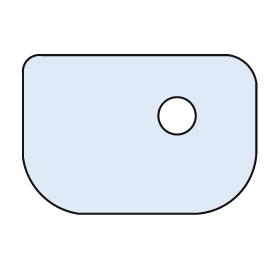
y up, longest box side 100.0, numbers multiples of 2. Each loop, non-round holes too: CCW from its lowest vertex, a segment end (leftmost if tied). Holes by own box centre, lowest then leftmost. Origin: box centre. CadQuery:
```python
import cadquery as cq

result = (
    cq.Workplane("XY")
    .moveTo(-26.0, -34.0)
    .lineTo(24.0, -34.0)
    .threePointArc((42.0, -26.0), (50.0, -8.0))
    .lineTo(50.0, 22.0)
    .threePointArc((46.0, 30.0), (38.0, 34.0))
    .lineTo(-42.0, 34.0)
    .threePointArc((-48.0, 32.0), (-50.0, 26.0))
    .lineTo(-50.0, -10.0)
    .threePointArc((-42.0, -26.0), (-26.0, -34.0))
    .close()
    .moveTo(16.0, 8.0)
    .circle(8.0)
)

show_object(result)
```